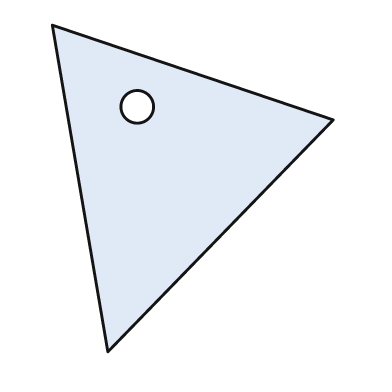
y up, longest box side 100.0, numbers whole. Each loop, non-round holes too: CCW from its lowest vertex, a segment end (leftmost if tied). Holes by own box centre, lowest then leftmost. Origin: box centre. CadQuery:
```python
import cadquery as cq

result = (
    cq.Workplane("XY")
    .moveTo(-26.0, -50.0)
    .lineTo(43.0, 21.0)
    .lineTo(-43.0, 50.0)
    .close()
    .moveTo(-17.0, 25.0)
    .circle(5.0)
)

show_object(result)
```